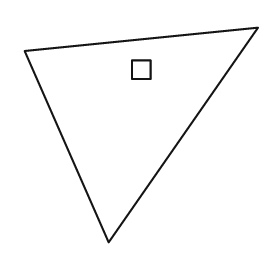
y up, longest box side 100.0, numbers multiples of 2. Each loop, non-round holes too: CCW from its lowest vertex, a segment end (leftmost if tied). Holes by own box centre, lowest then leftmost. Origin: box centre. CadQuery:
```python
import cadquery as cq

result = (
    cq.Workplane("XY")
    .moveTo(-14.0, -46.0)
    .lineTo(50.0, 46.0)
    .lineTo(-50.0, 36.0)
    .close()
    .moveTo(-4.0, 24.0)
    .lineTo(4.0, 24.0)
    .lineTo(4.0, 32.0)
    .lineTo(-4.0, 32.0)
    .close()
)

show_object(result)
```